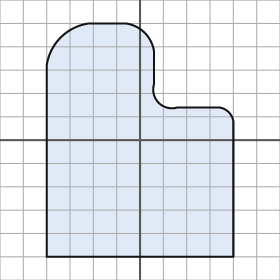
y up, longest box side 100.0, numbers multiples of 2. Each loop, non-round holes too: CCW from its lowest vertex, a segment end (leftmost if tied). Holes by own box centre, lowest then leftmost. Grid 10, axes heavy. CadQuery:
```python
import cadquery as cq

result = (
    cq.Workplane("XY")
    .moveTo(-40.0, -50.0)
    .lineTo(40.0, -50.0)
    .lineTo(40.0, 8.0)
    .threePointArc((38.0, 12.0), (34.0, 14.0))
    .lineTo(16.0, 14.0)
    .threePointArc((8.0, 16.0), (6.0, 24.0))
    .lineTo(6.0, 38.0)
    .threePointArc((2.0, 46.0), (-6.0, 50.0))
    .lineTo(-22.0, 50.0)
    .threePointArc((-34.0, 44.0), (-40.0, 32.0))
    .close()
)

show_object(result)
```